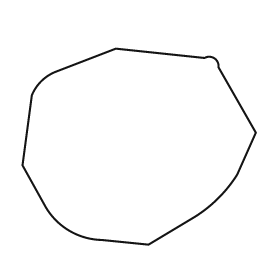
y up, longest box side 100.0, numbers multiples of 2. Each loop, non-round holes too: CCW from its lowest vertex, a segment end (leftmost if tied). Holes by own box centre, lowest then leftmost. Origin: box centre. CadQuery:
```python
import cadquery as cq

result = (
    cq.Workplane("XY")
    .moveTo(4.0, -42.0)
    .lineTo(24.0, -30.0)
    .threePointArc((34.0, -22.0), (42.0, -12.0))
    .lineTo(50.0, 6.0)
    .lineTo(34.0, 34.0)
    .threePointArc((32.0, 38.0), (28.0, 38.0))
    .lineTo(-10.0, 42.0)
    .lineTo(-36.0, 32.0)
    .threePointArc((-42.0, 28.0), (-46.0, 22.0))
    .lineTo(-50.0, -8.0)
    .lineTo(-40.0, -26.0)
    .threePointArc((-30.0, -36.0), (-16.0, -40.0))
    .close()
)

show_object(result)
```